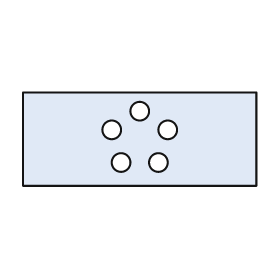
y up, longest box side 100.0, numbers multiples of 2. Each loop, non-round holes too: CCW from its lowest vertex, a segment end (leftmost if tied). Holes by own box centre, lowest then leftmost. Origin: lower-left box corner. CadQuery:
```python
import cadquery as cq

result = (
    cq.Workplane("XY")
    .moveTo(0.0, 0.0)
    .lineTo(100.0, 0.0)
    .lineTo(100.0, 40.0)
    .lineTo(0.0, 40.0)
    .close()
    .moveTo(42.0, 10.0)
    .circle(4.0)
    .moveTo(58.0, 10.0)
    .circle(4.0)
    .moveTo(38.0, 24.0)
    .circle(4.0)
    .moveTo(62.0, 24.0)
    .circle(4.0)
    .moveTo(50.0, 32.0)
    .circle(4.0)
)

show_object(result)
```